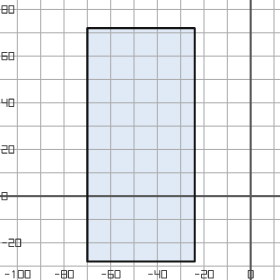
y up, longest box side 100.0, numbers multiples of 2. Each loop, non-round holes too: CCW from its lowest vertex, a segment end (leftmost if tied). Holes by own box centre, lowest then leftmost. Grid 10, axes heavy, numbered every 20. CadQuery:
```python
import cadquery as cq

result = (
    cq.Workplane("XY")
    .moveTo(-70.0, -28.0)
    .lineTo(-24.0, -28.0)
    .lineTo(-24.0, 72.0)
    .lineTo(-70.0, 72.0)
    .close()
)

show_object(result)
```